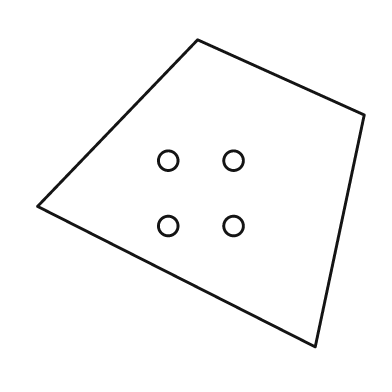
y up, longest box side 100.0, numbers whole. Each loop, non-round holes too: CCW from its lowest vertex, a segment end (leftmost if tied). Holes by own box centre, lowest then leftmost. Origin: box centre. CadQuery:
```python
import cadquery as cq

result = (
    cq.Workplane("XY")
    .moveTo(35.0, -47.0)
    .lineTo(50.0, 24.0)
    .lineTo(-1.0, 47.0)
    .lineTo(-50.0, -4.0)
    .close()
    .moveTo(-10.0, -10.0)
    .circle(3.0)
    .moveTo(10.0, -10.0)
    .circle(3.0)
    .moveTo(-10.0, 10.0)
    .circle(3.0)
    .moveTo(10.0, 10.0)
    .circle(3.0)
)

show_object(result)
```